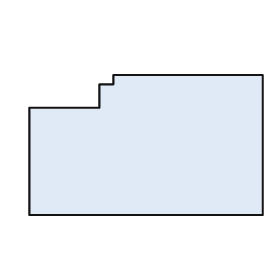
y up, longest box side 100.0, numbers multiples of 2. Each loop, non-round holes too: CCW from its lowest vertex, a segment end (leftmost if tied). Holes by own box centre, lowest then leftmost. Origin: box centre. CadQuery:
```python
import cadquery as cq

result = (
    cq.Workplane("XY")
    .moveTo(-50.0, -30.0)
    .lineTo(50.0, -30.0)
    .lineTo(50.0, 30.0)
    .lineTo(-14.0, 30.0)
    .lineTo(-14.0, 26.0)
    .lineTo(-20.0, 26.0)
    .lineTo(-20.0, 16.0)
    .lineTo(-50.0, 16.0)
    .close()
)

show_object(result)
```